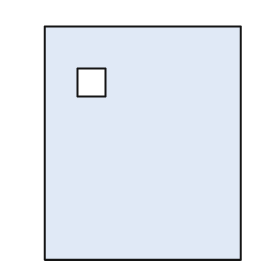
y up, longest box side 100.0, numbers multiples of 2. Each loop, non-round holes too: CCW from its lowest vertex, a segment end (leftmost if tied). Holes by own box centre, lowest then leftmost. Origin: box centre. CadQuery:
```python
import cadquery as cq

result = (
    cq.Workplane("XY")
    .moveTo(-42.0, -50.0)
    .lineTo(42.0, -50.0)
    .lineTo(42.0, 50.0)
    .lineTo(-42.0, 50.0)
    .close()
    .moveTo(-28.0, 20.0)
    .lineTo(-16.0, 20.0)
    .lineTo(-16.0, 32.0)
    .lineTo(-28.0, 32.0)
    .close()
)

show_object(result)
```